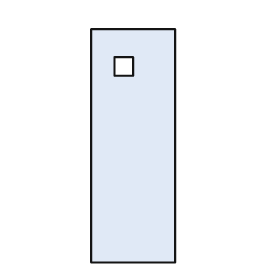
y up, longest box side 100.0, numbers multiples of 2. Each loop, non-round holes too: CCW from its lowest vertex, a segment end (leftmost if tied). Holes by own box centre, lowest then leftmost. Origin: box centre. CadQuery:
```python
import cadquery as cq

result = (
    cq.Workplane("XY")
    .moveTo(-18.0, -50.0)
    .lineTo(18.0, -50.0)
    .lineTo(18.0, 50.0)
    .lineTo(-18.0, 50.0)
    .close()
    .moveTo(-8.0, 30.0)
    .lineTo(0.0, 30.0)
    .lineTo(0.0, 38.0)
    .lineTo(-8.0, 38.0)
    .close()
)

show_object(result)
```